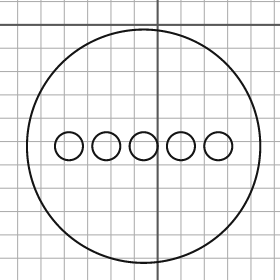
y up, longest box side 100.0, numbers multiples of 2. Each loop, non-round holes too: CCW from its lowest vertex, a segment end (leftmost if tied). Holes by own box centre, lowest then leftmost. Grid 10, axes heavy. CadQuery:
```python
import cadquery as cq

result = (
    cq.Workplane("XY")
    .moveTo(-6.0, -52.0)
    .circle(50.0)
    .moveTo(-38.0, -52.0)
    .circle(6.0)
    .moveTo(-22.0, -52.0)
    .circle(6.0)
    .moveTo(-6.0, -52.0)
    .circle(6.0)
    .moveTo(10.0, -52.0)
    .circle(6.0)
    .moveTo(26.0, -52.0)
    .circle(6.0)
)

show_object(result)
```